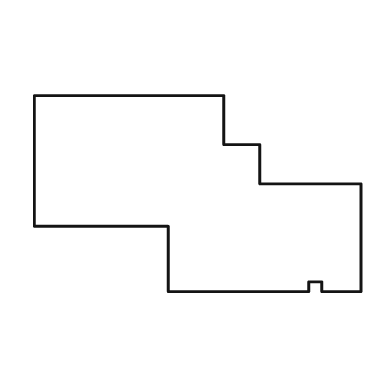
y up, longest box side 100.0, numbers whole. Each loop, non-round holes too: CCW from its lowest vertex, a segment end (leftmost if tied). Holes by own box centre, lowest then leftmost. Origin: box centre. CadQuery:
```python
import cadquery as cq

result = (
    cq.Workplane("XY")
    .moveTo(-9.0, -30.0)
    .lineTo(34.0, -30.0)
    .lineTo(34.0, -27.0)
    .lineTo(38.0, -27.0)
    .lineTo(38.0, -30.0)
    .lineTo(50.0, -30.0)
    .lineTo(50.0, 3.0)
    .lineTo(19.0, 3.0)
    .lineTo(19.0, 15.0)
    .lineTo(8.0, 15.0)
    .lineTo(8.0, 30.0)
    .lineTo(-50.0, 30.0)
    .lineTo(-50.0, -10.0)
    .lineTo(-9.0, -10.0)
    .close()
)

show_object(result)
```